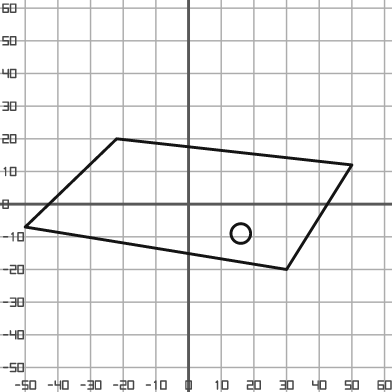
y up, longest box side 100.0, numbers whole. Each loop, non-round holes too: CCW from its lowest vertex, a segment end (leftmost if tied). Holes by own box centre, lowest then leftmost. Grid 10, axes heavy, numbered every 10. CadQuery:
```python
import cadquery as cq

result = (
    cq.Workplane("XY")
    .moveTo(30.0, -20.0)
    .lineTo(50.0, 12.0)
    .lineTo(-22.0, 20.0)
    .lineTo(-50.0, -7.0)
    .close()
    .moveTo(16.0, -9.0)
    .circle(3.0)
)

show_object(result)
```